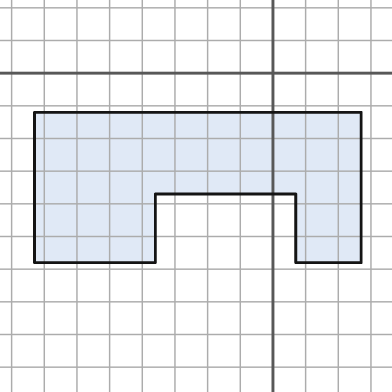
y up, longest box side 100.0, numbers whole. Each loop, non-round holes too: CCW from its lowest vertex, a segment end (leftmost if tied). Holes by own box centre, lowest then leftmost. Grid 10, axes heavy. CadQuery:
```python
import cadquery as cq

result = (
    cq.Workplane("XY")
    .moveTo(-73.0, -58.0)
    .lineTo(-36.0, -58.0)
    .lineTo(-36.0, -37.0)
    .lineTo(7.0, -37.0)
    .lineTo(7.0, -58.0)
    .lineTo(27.0, -58.0)
    .lineTo(27.0, -12.0)
    .lineTo(-73.0, -12.0)
    .close()
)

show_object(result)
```